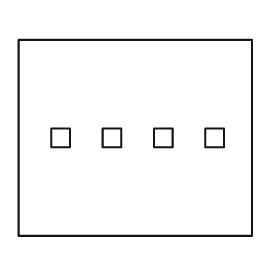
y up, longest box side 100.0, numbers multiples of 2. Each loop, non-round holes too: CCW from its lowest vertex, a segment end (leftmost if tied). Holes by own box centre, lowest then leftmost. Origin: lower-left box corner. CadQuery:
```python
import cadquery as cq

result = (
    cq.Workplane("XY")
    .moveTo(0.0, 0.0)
    .lineTo(100.0, 0.0)
    .lineTo(100.0, 84.0)
    .lineTo(0.0, 84.0)
    .close()
    .moveTo(14.0, 38.0)
    .lineTo(22.0, 38.0)
    .lineTo(22.0, 46.0)
    .lineTo(14.0, 46.0)
    .close()
    .moveTo(36.0, 38.0)
    .lineTo(44.0, 38.0)
    .lineTo(44.0, 46.0)
    .lineTo(36.0, 46.0)
    .close()
    .moveTo(58.0, 38.0)
    .lineTo(66.0, 38.0)
    .lineTo(66.0, 46.0)
    .lineTo(58.0, 46.0)
    .close()
    .moveTo(80.0, 38.0)
    .lineTo(88.0, 38.0)
    .lineTo(88.0, 46.0)
    .lineTo(80.0, 46.0)
    .close()
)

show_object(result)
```